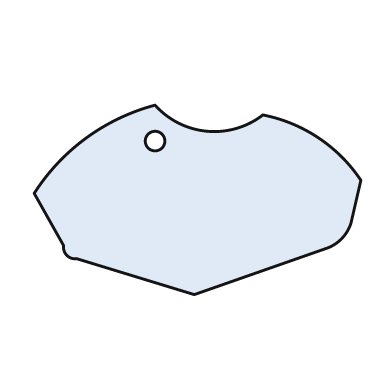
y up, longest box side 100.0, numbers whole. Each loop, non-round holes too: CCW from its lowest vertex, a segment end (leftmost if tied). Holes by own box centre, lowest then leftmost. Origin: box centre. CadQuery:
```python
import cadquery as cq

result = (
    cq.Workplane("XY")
    .moveTo(-1.0, -29.0)
    .lineTo(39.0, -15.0)
    .threePointArc((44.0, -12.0), (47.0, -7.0))
    .lineTo(50.0, 6.0)
    .threePointArc((37.0, 19.0), (20.0, 26.0))
    .threePointArc((3.0, 21.0), (-13.0, 29.0))
    .threePointArc((-34.0, 19.0), (-50.0, 2.0))
    .lineTo(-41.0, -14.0)
    .threePointArc((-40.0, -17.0), (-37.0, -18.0))
    .close()
    .moveTo(-13.0, 18.0)
    .circle(3.0)
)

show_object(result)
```